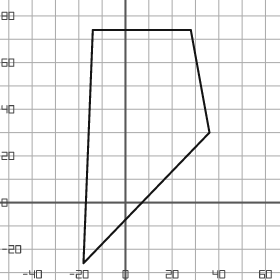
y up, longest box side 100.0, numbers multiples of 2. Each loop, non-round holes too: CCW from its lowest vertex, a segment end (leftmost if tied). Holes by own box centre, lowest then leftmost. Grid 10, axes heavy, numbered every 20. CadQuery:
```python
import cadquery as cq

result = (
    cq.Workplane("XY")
    .moveTo(-18.0, -26.0)
    .lineTo(36.0, 30.0)
    .lineTo(28.0, 74.0)
    .lineTo(-14.0, 74.0)
    .close()
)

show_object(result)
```